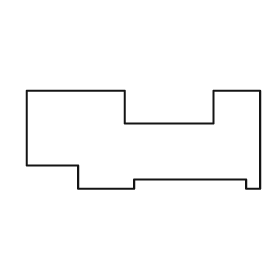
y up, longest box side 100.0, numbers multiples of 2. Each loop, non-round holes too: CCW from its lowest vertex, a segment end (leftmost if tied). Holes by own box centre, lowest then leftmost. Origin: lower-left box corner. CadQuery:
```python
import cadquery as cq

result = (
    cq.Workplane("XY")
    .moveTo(22.0, 0.0)
    .lineTo(46.0, 0.0)
    .lineTo(46.0, 4.0)
    .lineTo(94.0, 4.0)
    .lineTo(94.0, 0.0)
    .lineTo(100.0, 0.0)
    .lineTo(100.0, 42.0)
    .lineTo(80.0, 42.0)
    .lineTo(80.0, 28.0)
    .lineTo(42.0, 28.0)
    .lineTo(42.0, 42.0)
    .lineTo(0.0, 42.0)
    .lineTo(0.0, 10.0)
    .lineTo(22.0, 10.0)
    .close()
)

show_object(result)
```